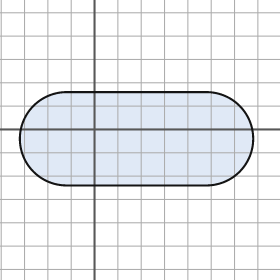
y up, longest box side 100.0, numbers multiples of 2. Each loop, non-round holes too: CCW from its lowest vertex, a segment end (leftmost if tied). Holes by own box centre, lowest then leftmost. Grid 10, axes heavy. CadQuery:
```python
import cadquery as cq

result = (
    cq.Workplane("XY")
    .moveTo(-12.0, -24.0)
    .lineTo(48.0, -24.0)
    .threePointArc((68.0, -4.0), (48.0, 16.0))
    .lineTo(-12.0, 16.0)
    .threePointArc((-32.0, -4.0), (-12.0, -24.0))
    .close()
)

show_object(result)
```